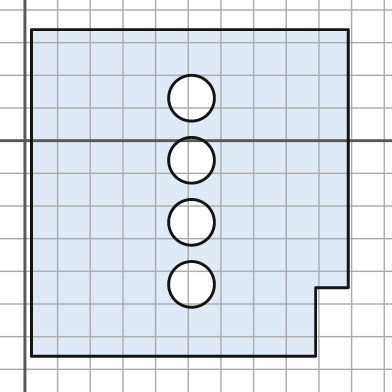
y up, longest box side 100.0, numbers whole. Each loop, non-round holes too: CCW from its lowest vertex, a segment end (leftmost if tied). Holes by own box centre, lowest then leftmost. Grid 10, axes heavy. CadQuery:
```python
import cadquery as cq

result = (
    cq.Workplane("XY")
    .moveTo(2.0, -66.0)
    .lineTo(89.0, -66.0)
    .lineTo(89.0, -45.0)
    .lineTo(99.0, -45.0)
    .lineTo(99.0, 34.0)
    .lineTo(2.0, 34.0)
    .close()
    .moveTo(51.0, -44.0)
    .circle(7.0)
    .moveTo(51.0, -25.0)
    .circle(7.0)
    .moveTo(51.0, -6.0)
    .circle(7.0)
    .moveTo(51.0, 13.0)
    .circle(7.0)
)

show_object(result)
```